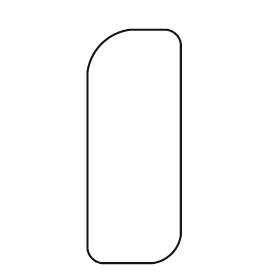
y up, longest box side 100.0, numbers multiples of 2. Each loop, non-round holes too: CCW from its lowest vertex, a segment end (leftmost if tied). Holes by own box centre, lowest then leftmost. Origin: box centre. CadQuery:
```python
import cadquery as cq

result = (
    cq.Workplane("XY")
    .moveTo(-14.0, -50.0)
    .lineTo(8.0, -50.0)
    .threePointArc((16.0, -46.0), (20.0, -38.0))
    .lineTo(20.0, 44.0)
    .threePointArc((18.0, 48.0), (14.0, 50.0))
    .lineTo(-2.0, 50.0)
    .threePointArc((-14.0, 44.0), (-20.0, 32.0))
    .lineTo(-20.0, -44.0)
    .threePointArc((-18.0, -48.0), (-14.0, -50.0))
    .close()
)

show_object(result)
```